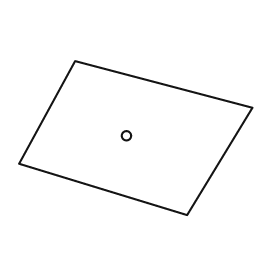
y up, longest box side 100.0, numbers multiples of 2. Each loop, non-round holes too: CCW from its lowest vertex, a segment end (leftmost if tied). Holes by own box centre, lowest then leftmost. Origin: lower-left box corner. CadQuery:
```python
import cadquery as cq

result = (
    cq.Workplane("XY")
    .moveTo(72.0, 0.0)
    .lineTo(100.0, 46.0)
    .lineTo(24.0, 66.0)
    .lineTo(0.0, 22.0)
    .close()
    .moveTo(46.0, 34.0)
    .circle(2.0)
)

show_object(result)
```